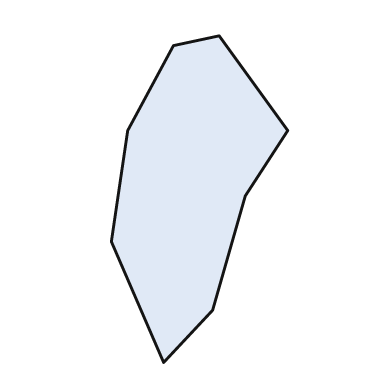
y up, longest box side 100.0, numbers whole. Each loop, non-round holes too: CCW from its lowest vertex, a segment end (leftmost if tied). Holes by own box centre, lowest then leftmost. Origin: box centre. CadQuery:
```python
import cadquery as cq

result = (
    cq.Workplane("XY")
    .moveTo(-11.0, -50.0)
    .lineTo(4.0, -34.0)
    .lineTo(14.0, 1.0)
    .lineTo(27.0, 21.0)
    .lineTo(6.0, 50.0)
    .lineTo(-8.0, 47.0)
    .lineTo(-22.0, 21.0)
    .lineTo(-27.0, -13.0)
    .close()
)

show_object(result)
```